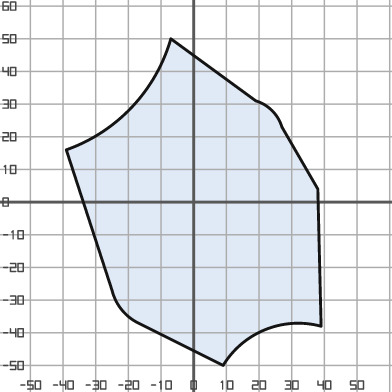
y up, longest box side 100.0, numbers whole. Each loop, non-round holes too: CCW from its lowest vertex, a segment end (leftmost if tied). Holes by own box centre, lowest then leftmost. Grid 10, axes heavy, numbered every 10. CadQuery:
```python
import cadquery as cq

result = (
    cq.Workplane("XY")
    .moveTo(9.0, -50.0)
    .threePointArc((22.0, -39.0), (39.0, -38.0))
    .lineTo(38.0, 4.0)
    .lineTo(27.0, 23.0)
    .threePointArc((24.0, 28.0), (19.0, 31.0))
    .lineTo(-7.0, 50.0)
    .threePointArc((-19.0, 29.0), (-39.0, 16.0))
    .lineTo(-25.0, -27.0)
    .threePointArc((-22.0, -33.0), (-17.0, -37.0))
    .close()
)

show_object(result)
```